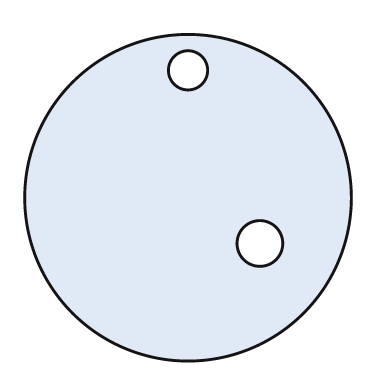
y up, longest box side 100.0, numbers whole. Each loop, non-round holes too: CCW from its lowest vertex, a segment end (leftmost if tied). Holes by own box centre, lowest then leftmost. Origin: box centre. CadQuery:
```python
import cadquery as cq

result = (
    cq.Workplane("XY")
    .moveTo(0.0, 0.0)
    .circle(50.0)
    .moveTo(22.0, -14.0)
    .circle(7.0)
    .moveTo(0.0, 39.0)
    .circle(6.0)
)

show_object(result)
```